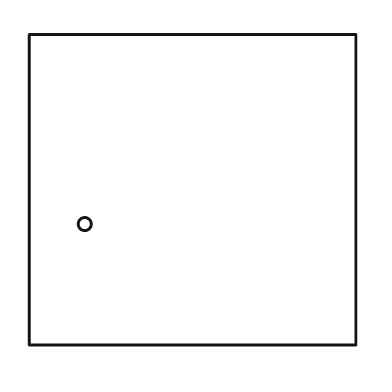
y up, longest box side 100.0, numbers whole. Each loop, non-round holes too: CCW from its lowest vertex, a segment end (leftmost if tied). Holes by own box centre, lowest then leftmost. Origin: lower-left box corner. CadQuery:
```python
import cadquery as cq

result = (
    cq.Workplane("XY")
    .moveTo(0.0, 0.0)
    .lineTo(100.0, 0.0)
    .lineTo(100.0, 95.0)
    .lineTo(0.0, 95.0)
    .close()
    .moveTo(17.0, 37.0)
    .circle(2.0)
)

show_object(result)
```